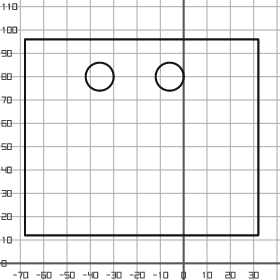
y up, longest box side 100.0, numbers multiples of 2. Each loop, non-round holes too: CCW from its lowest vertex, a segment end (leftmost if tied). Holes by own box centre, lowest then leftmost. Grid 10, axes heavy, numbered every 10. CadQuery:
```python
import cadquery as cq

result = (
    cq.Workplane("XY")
    .moveTo(-68.0, 12.0)
    .lineTo(32.0, 12.0)
    .lineTo(32.0, 96.0)
    .lineTo(-68.0, 96.0)
    .close()
    .moveTo(-36.0, 80.0)
    .circle(6.0)
    .moveTo(-6.0, 80.0)
    .circle(6.0)
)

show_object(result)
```